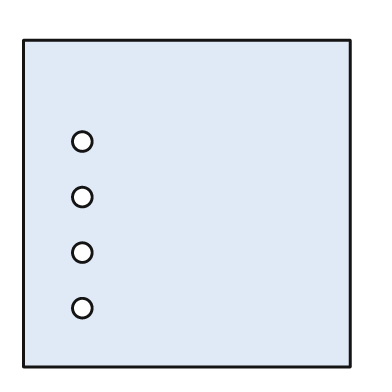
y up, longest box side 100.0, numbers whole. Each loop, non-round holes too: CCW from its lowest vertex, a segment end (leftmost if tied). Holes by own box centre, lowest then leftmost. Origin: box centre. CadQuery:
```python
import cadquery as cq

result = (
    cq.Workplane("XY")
    .moveTo(-50.0, -50.0)
    .lineTo(50.0, -50.0)
    .lineTo(50.0, 50.0)
    .lineTo(-50.0, 50.0)
    .close()
    .moveTo(-32.0, -32.0)
    .circle(3.0)
    .moveTo(-32.0, -15.0)
    .circle(3.0)
    .moveTo(-32.0, 2.0)
    .circle(3.0)
    .moveTo(-32.0, 19.0)
    .circle(3.0)
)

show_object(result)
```